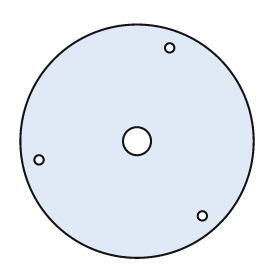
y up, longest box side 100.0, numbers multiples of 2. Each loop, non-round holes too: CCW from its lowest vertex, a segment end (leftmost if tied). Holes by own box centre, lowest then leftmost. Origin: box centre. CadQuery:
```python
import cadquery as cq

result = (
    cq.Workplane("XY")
    .moveTo(0.0, 0.0)
    .circle(50.0)
    .moveTo(28.0, -32.0)
    .circle(2.0)
    .moveTo(-42.0, -8.0)
    .circle(2.0)
    .moveTo(0.0, 0.0)
    .circle(6.0)
    .moveTo(14.0, 40.0)
    .circle(2.0)
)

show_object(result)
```